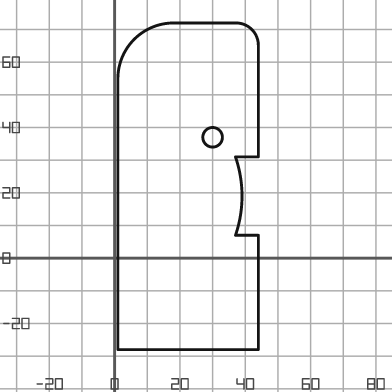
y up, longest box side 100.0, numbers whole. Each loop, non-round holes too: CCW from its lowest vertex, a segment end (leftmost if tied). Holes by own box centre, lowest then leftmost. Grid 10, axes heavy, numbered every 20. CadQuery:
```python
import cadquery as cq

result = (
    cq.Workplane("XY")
    .moveTo(1.0, -28.0)
    .lineTo(44.0, -28.0)
    .lineTo(44.0, 7.0)
    .lineTo(37.0, 7.0)
    .threePointArc((39.0, 19.0), (37.0, 31.0))
    .lineTo(44.0, 31.0)
    .lineTo(44.0, 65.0)
    .threePointArc((42.0, 70.0), (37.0, 72.0))
    .lineTo(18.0, 72.0)
    .threePointArc((6.0, 67.0), (1.0, 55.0))
    .close()
    .moveTo(30.0, 37.0)
    .circle(3.0)
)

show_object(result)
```